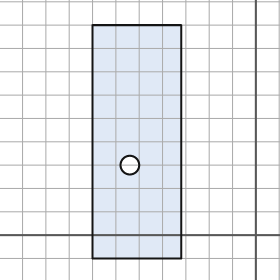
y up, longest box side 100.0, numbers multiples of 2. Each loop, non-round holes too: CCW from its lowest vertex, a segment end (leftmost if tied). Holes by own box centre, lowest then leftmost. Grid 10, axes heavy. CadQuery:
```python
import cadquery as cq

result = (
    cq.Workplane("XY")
    .moveTo(-70.0, -10.0)
    .lineTo(-32.0, -10.0)
    .lineTo(-32.0, 90.0)
    .lineTo(-70.0, 90.0)
    .close()
    .moveTo(-54.0, 30.0)
    .circle(4.0)
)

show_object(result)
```